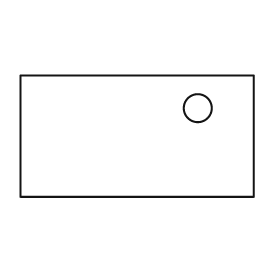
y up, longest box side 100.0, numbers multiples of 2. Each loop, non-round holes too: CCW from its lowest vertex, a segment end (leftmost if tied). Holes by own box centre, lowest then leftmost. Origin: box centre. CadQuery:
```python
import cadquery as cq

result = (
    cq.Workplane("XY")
    .moveTo(-50.0, -26.0)
    .lineTo(50.0, -26.0)
    .lineTo(50.0, 26.0)
    .lineTo(-50.0, 26.0)
    .close()
    .moveTo(26.0, 12.0)
    .circle(6.0)
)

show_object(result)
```